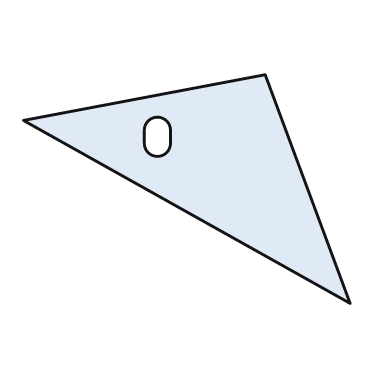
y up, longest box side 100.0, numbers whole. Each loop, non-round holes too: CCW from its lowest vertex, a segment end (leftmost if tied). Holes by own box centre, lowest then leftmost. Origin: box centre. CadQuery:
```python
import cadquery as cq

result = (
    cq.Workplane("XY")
    .moveTo(50.0, -35.0)
    .lineTo(24.0, 35.0)
    .lineTo(-50.0, 21.0)
    .close()
    .moveTo(-13.0, 14.0)
    .threePointArc((-9.0, 10.0), (-5.0, 14.0))
    .lineTo(-5.0, 18.0)
    .threePointArc((-9.0, 22.0), (-13.0, 18.0))
    .close()
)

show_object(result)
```